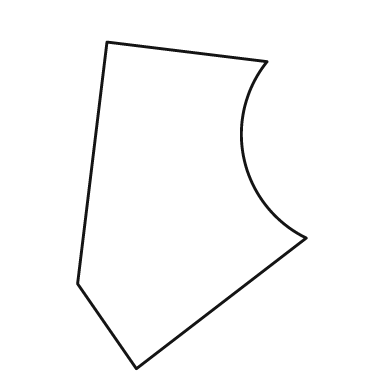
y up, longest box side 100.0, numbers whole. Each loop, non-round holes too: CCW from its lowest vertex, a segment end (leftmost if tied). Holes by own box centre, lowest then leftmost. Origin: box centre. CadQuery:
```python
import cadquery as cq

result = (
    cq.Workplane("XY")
    .moveTo(-17.0, -50.0)
    .lineTo(35.0, -10.0)
    .threePointArc((16.0, 14.0), (23.0, 44.0))
    .lineTo(-26.0, 50.0)
    .lineTo(-35.0, -24.0)
    .close()
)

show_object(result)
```